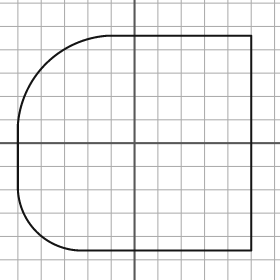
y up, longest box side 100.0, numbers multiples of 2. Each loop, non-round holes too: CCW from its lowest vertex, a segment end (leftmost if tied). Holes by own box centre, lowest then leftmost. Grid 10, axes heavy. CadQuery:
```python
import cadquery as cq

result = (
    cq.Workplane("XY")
    .moveTo(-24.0, -46.0)
    .lineTo(50.0, -46.0)
    .lineTo(50.0, 46.0)
    .lineTo(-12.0, 46.0)
    .threePointArc((-38.0, 34.0), (-50.0, 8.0))
    .lineTo(-50.0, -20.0)
    .threePointArc((-42.0, -38.0), (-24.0, -46.0))
    .close()
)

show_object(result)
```